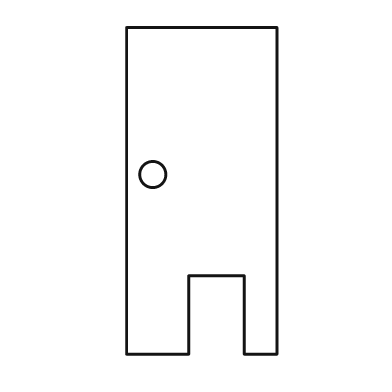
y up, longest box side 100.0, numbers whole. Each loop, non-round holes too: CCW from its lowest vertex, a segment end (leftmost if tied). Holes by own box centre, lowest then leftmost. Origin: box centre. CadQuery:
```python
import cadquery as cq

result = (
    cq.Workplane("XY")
    .moveTo(-23.0, -50.0)
    .lineTo(-4.0, -50.0)
    .lineTo(-4.0, -26.0)
    .lineTo(13.0, -26.0)
    .lineTo(13.0, -50.0)
    .lineTo(23.0, -50.0)
    .lineTo(23.0, 50.0)
    .lineTo(-23.0, 50.0)
    .close()
    .moveTo(-15.0, 5.0)
    .circle(4.0)
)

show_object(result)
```